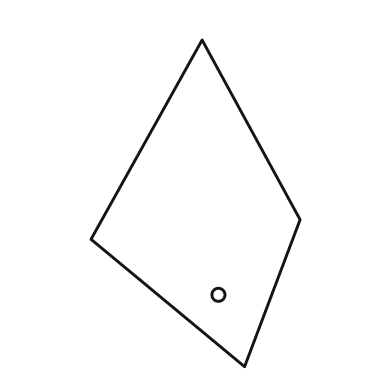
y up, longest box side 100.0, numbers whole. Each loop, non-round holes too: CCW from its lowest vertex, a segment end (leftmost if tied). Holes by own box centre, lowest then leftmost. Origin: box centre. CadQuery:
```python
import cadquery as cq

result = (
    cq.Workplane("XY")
    .moveTo(15.0, -50.0)
    .lineTo(32.0, -5.0)
    .lineTo(2.0, 50.0)
    .lineTo(-32.0, -11.0)
    .close()
    .moveTo(7.0, -28.0)
    .circle(2.0)
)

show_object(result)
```